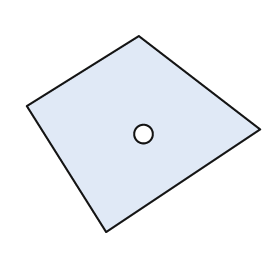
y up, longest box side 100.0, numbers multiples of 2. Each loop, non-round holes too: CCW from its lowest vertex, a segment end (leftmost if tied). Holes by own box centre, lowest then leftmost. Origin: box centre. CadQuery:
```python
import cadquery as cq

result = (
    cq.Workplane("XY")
    .moveTo(-16.0, -42.0)
    .lineTo(50.0, 2.0)
    .lineTo(-2.0, 42.0)
    .lineTo(-50.0, 12.0)
    .close()
    .moveTo(0.0, 0.0)
    .circle(4.0)
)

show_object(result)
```